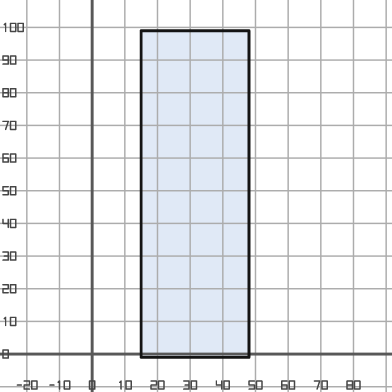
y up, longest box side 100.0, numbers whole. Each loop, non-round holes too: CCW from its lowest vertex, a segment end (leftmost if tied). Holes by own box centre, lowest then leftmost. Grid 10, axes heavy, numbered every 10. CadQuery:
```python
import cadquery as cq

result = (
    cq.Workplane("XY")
    .moveTo(15.0, -1.0)
    .lineTo(48.0, -1.0)
    .lineTo(48.0, 99.0)
    .lineTo(15.0, 99.0)
    .close()
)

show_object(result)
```